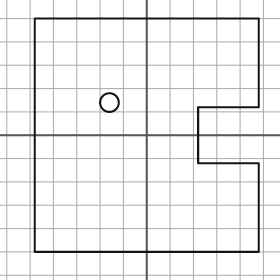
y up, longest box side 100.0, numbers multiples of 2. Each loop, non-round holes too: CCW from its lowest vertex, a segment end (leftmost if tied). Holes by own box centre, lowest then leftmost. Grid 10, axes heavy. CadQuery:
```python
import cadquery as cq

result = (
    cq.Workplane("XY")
    .moveTo(-48.0, -50.0)
    .lineTo(48.0, -50.0)
    .lineTo(48.0, -12.0)
    .lineTo(22.0, -12.0)
    .lineTo(22.0, 12.0)
    .lineTo(48.0, 12.0)
    .lineTo(48.0, 50.0)
    .lineTo(-48.0, 50.0)
    .close()
    .moveTo(-16.0, 14.0)
    .circle(4.0)
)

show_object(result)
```